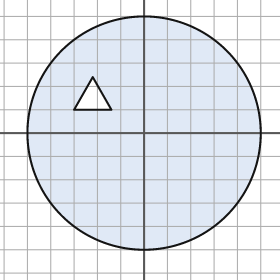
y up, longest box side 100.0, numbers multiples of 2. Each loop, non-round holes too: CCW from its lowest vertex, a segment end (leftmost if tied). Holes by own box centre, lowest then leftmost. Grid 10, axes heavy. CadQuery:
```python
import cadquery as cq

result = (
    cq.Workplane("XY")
    .moveTo(0.0, 0.0)
    .circle(50.0)
    .moveTo(-30.0, 10.0)
    .lineTo(-14.0, 10.0)
    .lineTo(-22.0, 24.0)
    .close()
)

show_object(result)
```